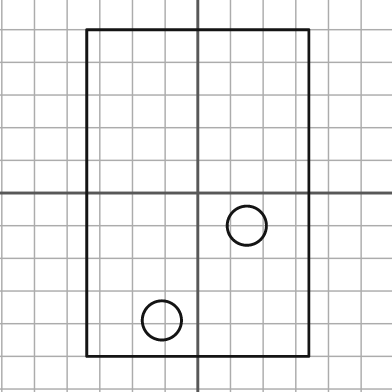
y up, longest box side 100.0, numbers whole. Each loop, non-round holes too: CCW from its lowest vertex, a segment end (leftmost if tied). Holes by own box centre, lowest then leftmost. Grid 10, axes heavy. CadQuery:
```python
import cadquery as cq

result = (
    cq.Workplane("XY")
    .moveTo(-34.0, -50.0)
    .lineTo(34.0, -50.0)
    .lineTo(34.0, 50.0)
    .lineTo(-34.0, 50.0)
    .close()
    .moveTo(-11.0, -39.0)
    .circle(6.0)
    .moveTo(15.0, -10.0)
    .circle(6.0)
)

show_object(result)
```